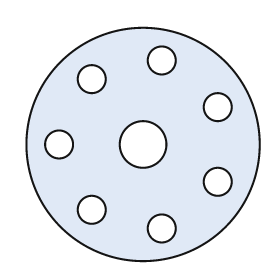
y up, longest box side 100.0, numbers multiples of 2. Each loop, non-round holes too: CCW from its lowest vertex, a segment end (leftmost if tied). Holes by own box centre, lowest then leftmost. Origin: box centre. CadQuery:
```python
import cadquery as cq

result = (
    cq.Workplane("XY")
    .moveTo(0.0, 0.0)
    .circle(50.0)
    .moveTo(8.0, -36.0)
    .circle(6.0)
    .moveTo(-22.0, -28.0)
    .circle(6.0)
    .moveTo(32.0, -16.0)
    .circle(6.0)
    .moveTo(-36.0, 0.0)
    .circle(6.0)
    .moveTo(0.0, 0.0)
    .circle(10.0)
    .moveTo(32.0, 16.0)
    .circle(6.0)
    .moveTo(-22.0, 28.0)
    .circle(6.0)
    .moveTo(8.0, 36.0)
    .circle(6.0)
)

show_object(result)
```